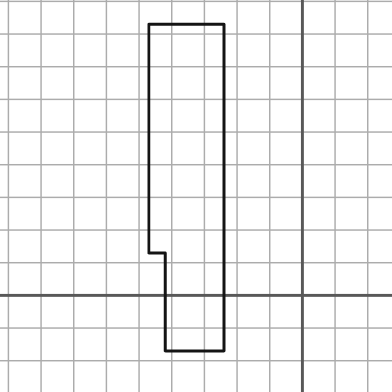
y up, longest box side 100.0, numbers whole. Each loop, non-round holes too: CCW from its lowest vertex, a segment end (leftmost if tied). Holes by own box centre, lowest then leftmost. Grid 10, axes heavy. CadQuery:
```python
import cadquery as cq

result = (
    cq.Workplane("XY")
    .moveTo(-42.0, -17.0)
    .lineTo(-24.0, -17.0)
    .lineTo(-24.0, 83.0)
    .lineTo(-47.0, 83.0)
    .lineTo(-47.0, 13.0)
    .lineTo(-42.0, 13.0)
    .close()
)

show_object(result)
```